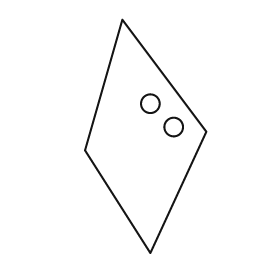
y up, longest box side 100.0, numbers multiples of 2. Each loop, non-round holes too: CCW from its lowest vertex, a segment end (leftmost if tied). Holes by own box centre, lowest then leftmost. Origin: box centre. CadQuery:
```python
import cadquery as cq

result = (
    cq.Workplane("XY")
    .moveTo(2.0, -50.0)
    .lineTo(26.0, 2.0)
    .lineTo(-10.0, 50.0)
    .lineTo(-26.0, -6.0)
    .close()
    .moveTo(12.0, 4.0)
    .circle(4.0)
    .moveTo(2.0, 14.0)
    .circle(4.0)
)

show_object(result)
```